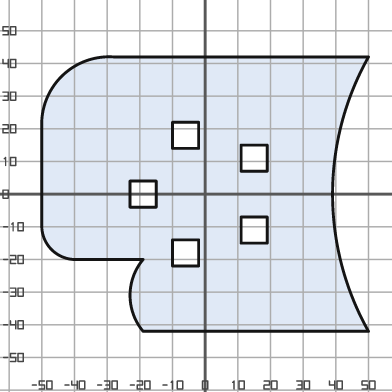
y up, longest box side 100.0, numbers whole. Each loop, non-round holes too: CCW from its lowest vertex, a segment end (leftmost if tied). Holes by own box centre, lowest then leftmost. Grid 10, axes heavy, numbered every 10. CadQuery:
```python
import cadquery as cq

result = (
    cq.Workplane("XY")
    .moveTo(-19.0, -42.0)
    .lineTo(50.0, -42.0)
    .threePointArc((39.0, 0.0), (50.0, 42.0))
    .lineTo(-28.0, 42.0)
    .threePointArc((-44.0, 36.0), (-50.0, 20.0))
    .lineTo(-50.0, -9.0)
    .threePointArc((-47.0, -17.0), (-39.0, -20.0))
    .lineTo(-19.0, -20.0)
    .threePointArc((-23.0, -31.0), (-19.0, -42.0))
    .close()
    .moveTo(-10.0, -22.0)
    .lineTo(-2.0, -22.0)
    .lineTo(-2.0, -14.0)
    .lineTo(-10.0, -14.0)
    .close()
    .moveTo(11.0, -15.0)
    .lineTo(19.0, -15.0)
    .lineTo(19.0, -7.0)
    .lineTo(11.0, -7.0)
    .close()
    .moveTo(-23.0, -4.0)
    .lineTo(-15.0, -4.0)
    .lineTo(-15.0, 4.0)
    .lineTo(-23.0, 4.0)
    .close()
    .moveTo(11.0, 7.0)
    .lineTo(19.0, 7.0)
    .lineTo(19.0, 15.0)
    .lineTo(11.0, 15.0)
    .close()
    .moveTo(-10.0, 14.0)
    .lineTo(-2.0, 14.0)
    .lineTo(-2.0, 22.0)
    .lineTo(-10.0, 22.0)
    .close()
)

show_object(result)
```